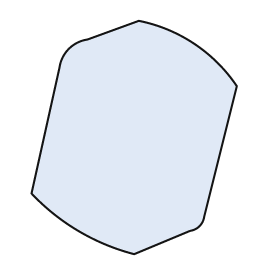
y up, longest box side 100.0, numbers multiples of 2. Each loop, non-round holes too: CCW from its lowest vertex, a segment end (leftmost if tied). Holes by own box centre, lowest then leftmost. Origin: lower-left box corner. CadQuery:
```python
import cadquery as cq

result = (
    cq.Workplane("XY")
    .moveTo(44.0, 0.0)
    .lineTo(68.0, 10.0)
    .threePointArc((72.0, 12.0), (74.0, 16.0))
    .lineTo(88.0, 72.0)
    .threePointArc((70.0, 90.0), (46.0, 100.0))
    .lineTo(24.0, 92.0)
    .threePointArc((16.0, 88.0), (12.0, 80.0))
    .lineTo(0.0, 26.0)
    .threePointArc((20.0, 10.0), (44.0, 0.0))
    .close()
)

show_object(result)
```